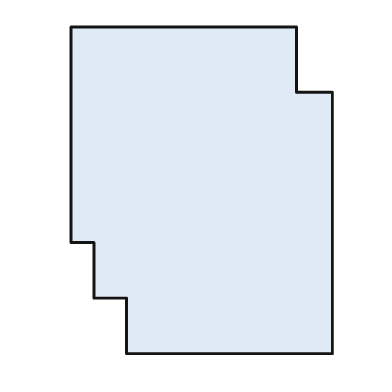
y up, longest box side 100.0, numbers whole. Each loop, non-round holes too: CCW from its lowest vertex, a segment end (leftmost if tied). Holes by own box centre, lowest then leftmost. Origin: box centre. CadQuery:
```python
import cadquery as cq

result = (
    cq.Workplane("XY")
    .moveTo(-23.0, -50.0)
    .lineTo(40.0, -50.0)
    .lineTo(40.0, 30.0)
    .lineTo(29.0, 30.0)
    .lineTo(29.0, 50.0)
    .lineTo(-40.0, 50.0)
    .lineTo(-40.0, -16.0)
    .lineTo(-33.0, -16.0)
    .lineTo(-33.0, -33.0)
    .lineTo(-23.0, -33.0)
    .close()
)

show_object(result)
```